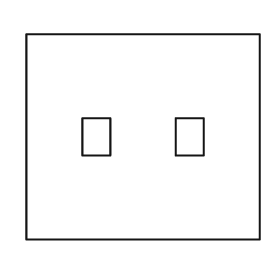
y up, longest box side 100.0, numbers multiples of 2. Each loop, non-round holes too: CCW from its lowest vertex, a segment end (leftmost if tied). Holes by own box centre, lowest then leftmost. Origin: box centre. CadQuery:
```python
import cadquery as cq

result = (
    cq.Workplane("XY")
    .moveTo(-50.0, -44.0)
    .lineTo(50.0, -44.0)
    .lineTo(50.0, 44.0)
    .lineTo(-50.0, 44.0)
    .close()
    .moveTo(-26.0, -8.0)
    .lineTo(-14.0, -8.0)
    .lineTo(-14.0, 8.0)
    .lineTo(-26.0, 8.0)
    .close()
    .moveTo(14.0, -8.0)
    .lineTo(26.0, -8.0)
    .lineTo(26.0, 8.0)
    .lineTo(14.0, 8.0)
    .close()
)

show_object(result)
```